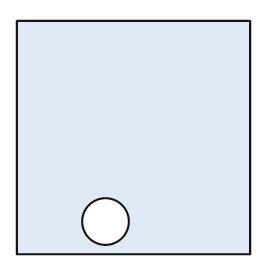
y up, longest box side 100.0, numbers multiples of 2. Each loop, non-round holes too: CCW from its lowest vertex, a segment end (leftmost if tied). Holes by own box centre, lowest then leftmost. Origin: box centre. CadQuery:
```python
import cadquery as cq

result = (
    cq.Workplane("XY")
    .moveTo(-50.0, -50.0)
    .lineTo(50.0, -50.0)
    .lineTo(50.0, 50.0)
    .lineTo(-50.0, 50.0)
    .close()
    .moveTo(-12.0, -36.0)
    .circle(10.0)
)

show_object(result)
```